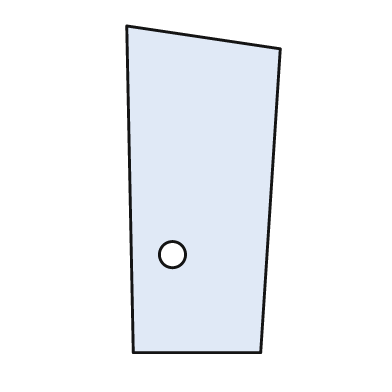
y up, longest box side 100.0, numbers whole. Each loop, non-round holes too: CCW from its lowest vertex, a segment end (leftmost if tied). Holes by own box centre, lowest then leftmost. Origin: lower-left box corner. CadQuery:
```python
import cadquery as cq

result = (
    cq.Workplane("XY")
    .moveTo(2.0, 0.0)
    .lineTo(41.0, 0.0)
    .lineTo(47.0, 93.0)
    .lineTo(0.0, 100.0)
    .close()
    .moveTo(14.0, 30.0)
    .circle(4.0)
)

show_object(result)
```